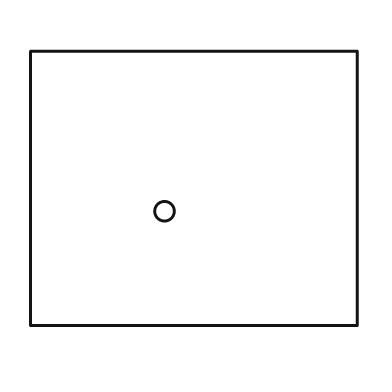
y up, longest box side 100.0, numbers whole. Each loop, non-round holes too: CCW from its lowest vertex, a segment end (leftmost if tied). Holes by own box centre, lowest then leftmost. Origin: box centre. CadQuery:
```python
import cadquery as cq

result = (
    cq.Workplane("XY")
    .moveTo(-50.0, -42.0)
    .lineTo(50.0, -42.0)
    .lineTo(50.0, 42.0)
    .lineTo(-50.0, 42.0)
    .close()
    .moveTo(-9.0, -7.0)
    .circle(3.0)
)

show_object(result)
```